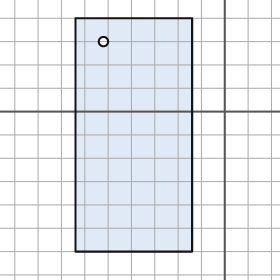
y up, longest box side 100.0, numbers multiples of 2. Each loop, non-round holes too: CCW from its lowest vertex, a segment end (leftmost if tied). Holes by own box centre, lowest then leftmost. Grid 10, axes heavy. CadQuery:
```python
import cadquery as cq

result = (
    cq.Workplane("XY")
    .moveTo(-64.0, -60.0)
    .lineTo(-14.0, -60.0)
    .lineTo(-14.0, 40.0)
    .lineTo(-64.0, 40.0)
    .close()
    .moveTo(-52.0, 30.0)
    .circle(2.0)
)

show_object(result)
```